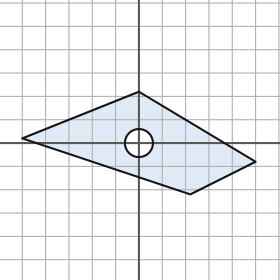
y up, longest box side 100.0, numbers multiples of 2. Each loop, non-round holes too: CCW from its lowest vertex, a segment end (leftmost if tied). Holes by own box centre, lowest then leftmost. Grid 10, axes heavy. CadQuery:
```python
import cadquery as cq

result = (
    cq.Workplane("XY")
    .moveTo(22.0, -22.0)
    .lineTo(50.0, -8.0)
    .lineTo(0.0, 22.0)
    .lineTo(-50.0, 2.0)
    .close()
    .moveTo(0.0, 0.0)
    .circle(6.0)
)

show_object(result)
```